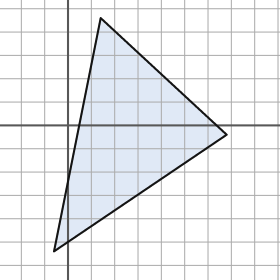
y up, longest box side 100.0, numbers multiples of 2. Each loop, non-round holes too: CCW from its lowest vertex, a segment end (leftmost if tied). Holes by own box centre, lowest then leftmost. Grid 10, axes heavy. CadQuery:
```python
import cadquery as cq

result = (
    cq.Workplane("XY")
    .moveTo(-6.0, -54.0)
    .lineTo(68.0, -4.0)
    .lineTo(14.0, 46.0)
    .close()
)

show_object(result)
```